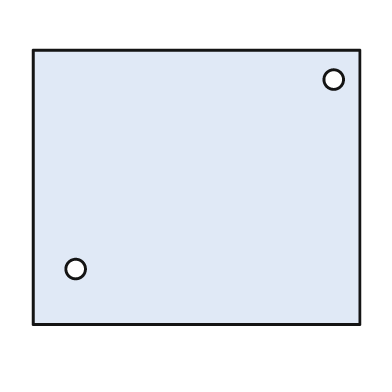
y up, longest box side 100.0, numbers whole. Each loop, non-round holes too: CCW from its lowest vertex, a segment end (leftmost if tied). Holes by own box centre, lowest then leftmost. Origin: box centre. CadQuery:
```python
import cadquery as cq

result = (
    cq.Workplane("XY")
    .moveTo(-50.0, -42.0)
    .lineTo(50.0, -42.0)
    .lineTo(50.0, 42.0)
    .lineTo(-50.0, 42.0)
    .close()
    .moveTo(-37.0, -25.0)
    .circle(3.0)
    .moveTo(42.0, 33.0)
    .circle(3.0)
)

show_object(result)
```